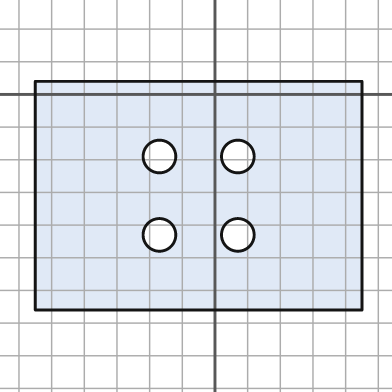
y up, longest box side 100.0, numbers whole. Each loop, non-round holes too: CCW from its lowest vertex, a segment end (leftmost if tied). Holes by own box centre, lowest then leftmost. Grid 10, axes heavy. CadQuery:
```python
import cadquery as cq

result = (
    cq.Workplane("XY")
    .moveTo(-55.0, -66.0)
    .lineTo(45.0, -66.0)
    .lineTo(45.0, 4.0)
    .lineTo(-55.0, 4.0)
    .close()
    .moveTo(-17.0, -43.0)
    .circle(5.0)
    .moveTo(7.0, -43.0)
    .circle(5.0)
    .moveTo(-17.0, -19.0)
    .circle(5.0)
    .moveTo(7.0, -19.0)
    .circle(5.0)
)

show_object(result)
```